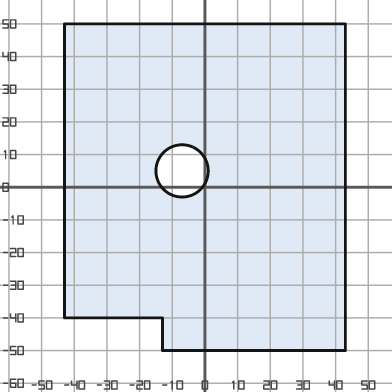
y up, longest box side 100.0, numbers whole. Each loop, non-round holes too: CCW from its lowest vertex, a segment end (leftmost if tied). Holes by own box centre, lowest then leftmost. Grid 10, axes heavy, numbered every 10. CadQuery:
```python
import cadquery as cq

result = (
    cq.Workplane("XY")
    .moveTo(-13.0, -50.0)
    .lineTo(43.0, -50.0)
    .lineTo(43.0, 50.0)
    .lineTo(-43.0, 50.0)
    .lineTo(-43.0, -40.0)
    .lineTo(-13.0, -40.0)
    .close()
    .moveTo(-7.0, 5.0)
    .circle(8.0)
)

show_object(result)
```